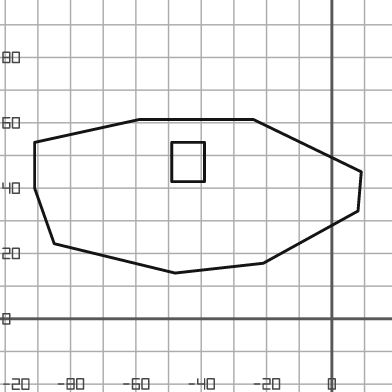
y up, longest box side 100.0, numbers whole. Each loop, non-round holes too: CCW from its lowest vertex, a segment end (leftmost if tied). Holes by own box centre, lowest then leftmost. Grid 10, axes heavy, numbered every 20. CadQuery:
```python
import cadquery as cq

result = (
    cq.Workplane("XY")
    .moveTo(-48.0, 14.0)
    .lineTo(-21.0, 17.0)
    .lineTo(8.0, 33.0)
    .lineTo(9.0, 45.0)
    .lineTo(-24.0, 61.0)
    .lineTo(-59.0, 61.0)
    .lineTo(-91.0, 54.0)
    .lineTo(-91.0, 40.0)
    .lineTo(-85.0, 23.0)
    .close()
    .moveTo(-49.0, 42.0)
    .lineTo(-39.0, 42.0)
    .lineTo(-39.0, 54.0)
    .lineTo(-49.0, 54.0)
    .close()
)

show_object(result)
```